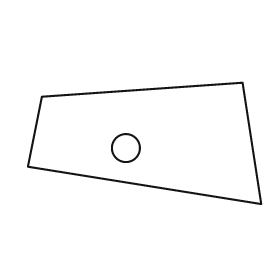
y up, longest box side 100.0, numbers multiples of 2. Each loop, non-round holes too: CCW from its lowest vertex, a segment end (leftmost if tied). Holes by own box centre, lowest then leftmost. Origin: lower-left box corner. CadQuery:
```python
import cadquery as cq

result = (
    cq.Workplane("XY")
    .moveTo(100.0, 0.0)
    .lineTo(92.0, 52.0)
    .lineTo(6.0, 46.0)
    .lineTo(0.0, 16.0)
    .close()
    .moveTo(42.0, 24.0)
    .circle(6.0)
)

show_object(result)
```